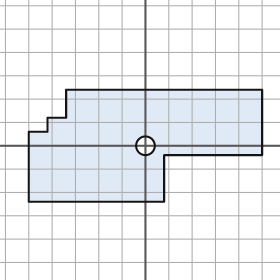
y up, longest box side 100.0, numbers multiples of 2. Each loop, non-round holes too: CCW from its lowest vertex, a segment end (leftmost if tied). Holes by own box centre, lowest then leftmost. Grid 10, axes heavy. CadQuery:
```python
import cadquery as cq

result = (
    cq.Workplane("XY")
    .moveTo(-50.0, -24.0)
    .lineTo(8.0, -24.0)
    .lineTo(8.0, -4.0)
    .lineTo(50.0, -4.0)
    .lineTo(50.0, 24.0)
    .lineTo(-34.0, 24.0)
    .lineTo(-34.0, 12.0)
    .lineTo(-42.0, 12.0)
    .lineTo(-42.0, 6.0)
    .lineTo(-50.0, 6.0)
    .close()
    .moveTo(0.0, 0.0)
    .circle(4.0)
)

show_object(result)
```